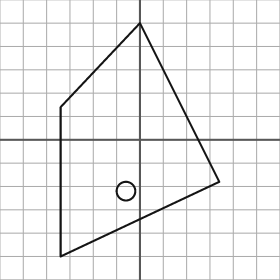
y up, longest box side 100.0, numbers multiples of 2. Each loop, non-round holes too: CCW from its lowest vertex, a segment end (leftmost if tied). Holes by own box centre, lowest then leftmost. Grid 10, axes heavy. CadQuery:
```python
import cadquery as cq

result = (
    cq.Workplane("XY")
    .moveTo(-34.0, -50.0)
    .lineTo(34.0, -18.0)
    .lineTo(0.0, 50.0)
    .lineTo(-34.0, 14.0)
    .close()
    .moveTo(-6.0, -22.0)
    .circle(4.0)
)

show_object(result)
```